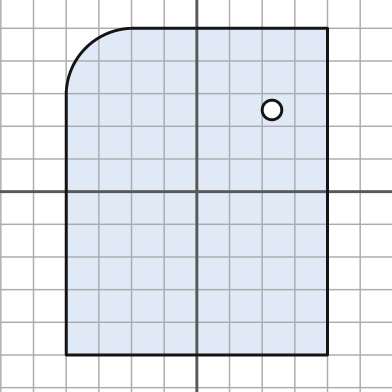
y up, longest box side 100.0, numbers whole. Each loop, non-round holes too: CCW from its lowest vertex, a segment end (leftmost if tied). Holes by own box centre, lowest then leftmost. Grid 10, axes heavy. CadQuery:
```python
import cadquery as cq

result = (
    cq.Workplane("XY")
    .moveTo(-40.0, -50.0)
    .lineTo(40.0, -50.0)
    .lineTo(40.0, 50.0)
    .lineTo(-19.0, 50.0)
    .threePointArc((-34.0, 44.0), (-40.0, 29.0))
    .close()
    .moveTo(23.0, 25.0)
    .circle(3.0)
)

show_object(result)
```